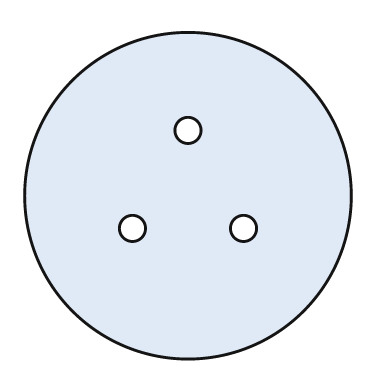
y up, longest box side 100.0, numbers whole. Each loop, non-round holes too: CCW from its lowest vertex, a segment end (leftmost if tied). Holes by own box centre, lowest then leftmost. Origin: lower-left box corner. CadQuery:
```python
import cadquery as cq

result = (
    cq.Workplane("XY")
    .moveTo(50.0, 50.0)
    .circle(50.0)
    .moveTo(33.0, 40.0)
    .circle(4.0)
    .moveTo(67.0, 40.0)
    .circle(4.0)
    .moveTo(50.0, 70.0)
    .circle(4.0)
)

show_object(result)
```